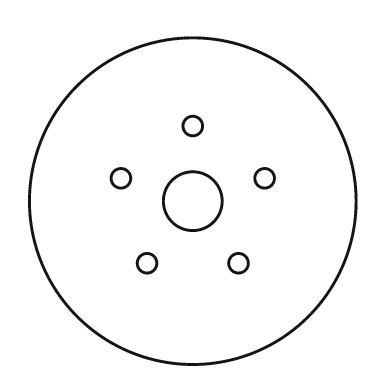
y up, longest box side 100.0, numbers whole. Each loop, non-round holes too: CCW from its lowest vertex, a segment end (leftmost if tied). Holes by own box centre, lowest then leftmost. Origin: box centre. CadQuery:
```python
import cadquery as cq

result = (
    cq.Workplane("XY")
    .moveTo(0.0, 0.0)
    .circle(50.0)
    .moveTo(-14.0, -19.0)
    .circle(3.0)
    .moveTo(14.0, -19.0)
    .circle(3.0)
    .moveTo(0.0, 0.0)
    .circle(9.0)
    .moveTo(-22.0, 7.0)
    .circle(3.0)
    .moveTo(22.0, 7.0)
    .circle(3.0)
    .moveTo(0.0, 23.0)
    .circle(3.0)
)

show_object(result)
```